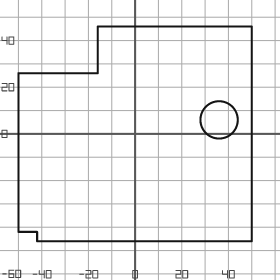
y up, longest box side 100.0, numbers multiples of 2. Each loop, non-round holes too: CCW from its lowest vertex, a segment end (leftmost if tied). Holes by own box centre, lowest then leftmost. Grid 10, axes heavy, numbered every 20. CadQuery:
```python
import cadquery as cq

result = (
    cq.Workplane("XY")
    .moveTo(-42.0, -46.0)
    .lineTo(50.0, -46.0)
    .lineTo(50.0, 46.0)
    .lineTo(-16.0, 46.0)
    .lineTo(-16.0, 26.0)
    .lineTo(-50.0, 26.0)
    .lineTo(-50.0, -42.0)
    .lineTo(-42.0, -42.0)
    .close()
    .moveTo(36.0, 6.0)
    .circle(8.0)
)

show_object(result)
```